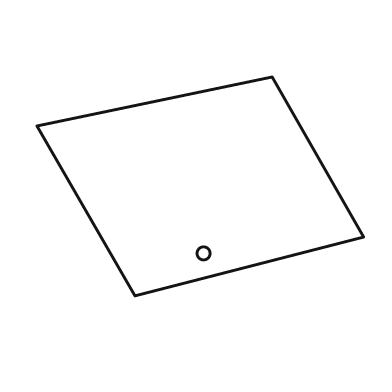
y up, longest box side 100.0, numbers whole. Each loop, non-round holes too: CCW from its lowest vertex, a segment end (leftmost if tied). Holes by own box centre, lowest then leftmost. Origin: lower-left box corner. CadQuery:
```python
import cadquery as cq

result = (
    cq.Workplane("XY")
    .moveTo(30.0, 0.0)
    .lineTo(100.0, 18.0)
    .lineTo(72.0, 67.0)
    .lineTo(0.0, 52.0)
    .close()
    .moveTo(51.0, 13.0)
    .circle(2.0)
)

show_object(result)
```